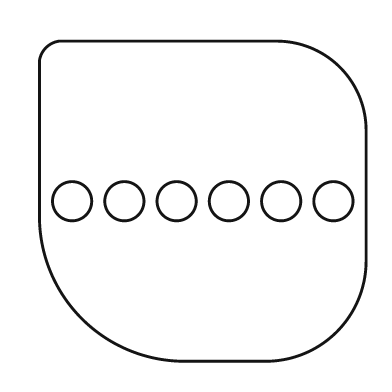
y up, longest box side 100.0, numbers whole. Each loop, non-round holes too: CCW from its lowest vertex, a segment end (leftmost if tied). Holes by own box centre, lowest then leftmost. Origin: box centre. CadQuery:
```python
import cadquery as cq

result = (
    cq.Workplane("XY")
    .moveTo(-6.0, -49.0)
    .lineTo(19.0, -49.0)
    .threePointArc((41.0, -40.0), (50.0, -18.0))
    .lineTo(50.0, 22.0)
    .threePointArc((42.0, 41.0), (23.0, 49.0))
    .lineTo(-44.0, 49.0)
    .threePointArc((-48.0, 47.0), (-50.0, 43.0))
    .lineTo(-50.0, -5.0)
    .threePointArc((-37.0, -36.0), (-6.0, -49.0))
    .close()
    .moveTo(-40.0, 0.0)
    .circle(6.0)
    .moveTo(-24.0, 0.0)
    .circle(6.0)
    .moveTo(-8.0, 0.0)
    .circle(6.0)
    .moveTo(8.0, 0.0)
    .circle(6.0)
    .moveTo(24.0, 0.0)
    .circle(6.0)
    .moveTo(40.0, 0.0)
    .circle(6.0)
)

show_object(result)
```